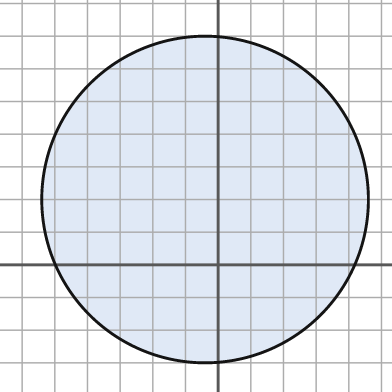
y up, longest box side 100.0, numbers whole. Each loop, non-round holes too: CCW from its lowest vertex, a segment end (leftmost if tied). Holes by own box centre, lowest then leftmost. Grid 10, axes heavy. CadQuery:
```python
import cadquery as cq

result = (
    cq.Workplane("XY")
    .moveTo(-4.0, 20.0)
    .circle(50.0)
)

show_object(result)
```